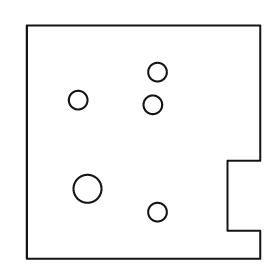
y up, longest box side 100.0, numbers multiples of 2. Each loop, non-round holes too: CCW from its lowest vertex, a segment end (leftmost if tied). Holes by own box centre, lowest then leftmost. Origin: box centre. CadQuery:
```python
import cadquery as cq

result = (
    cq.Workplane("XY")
    .moveTo(-50.0, -50.0)
    .lineTo(50.0, -50.0)
    .lineTo(50.0, -38.0)
    .lineTo(36.0, -38.0)
    .lineTo(36.0, -8.0)
    .lineTo(50.0, -8.0)
    .lineTo(50.0, 50.0)
    .lineTo(-50.0, 50.0)
    .close()
    .moveTo(6.0, -30.0)
    .circle(4.0)
    .moveTo(-24.0, -20.0)
    .circle(6.0)
    .moveTo(4.0, 16.0)
    .circle(4.0)
    .moveTo(-28.0, 18.0)
    .circle(4.0)
    .moveTo(6.0, 30.0)
    .circle(4.0)
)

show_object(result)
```